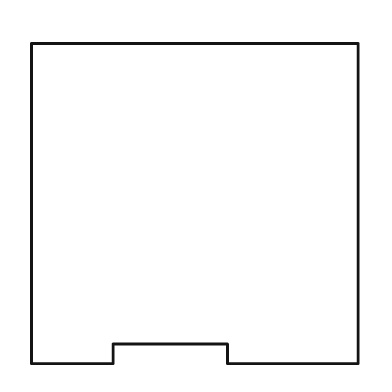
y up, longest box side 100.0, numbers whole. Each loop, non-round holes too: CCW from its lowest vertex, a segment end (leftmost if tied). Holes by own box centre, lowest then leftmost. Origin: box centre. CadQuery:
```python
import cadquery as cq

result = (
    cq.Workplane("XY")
    .moveTo(-50.0, -49.0)
    .lineTo(-25.0, -49.0)
    .lineTo(-25.0, -43.0)
    .lineTo(10.0, -43.0)
    .lineTo(10.0, -49.0)
    .lineTo(50.0, -49.0)
    .lineTo(50.0, 49.0)
    .lineTo(-50.0, 49.0)
    .close()
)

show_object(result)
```